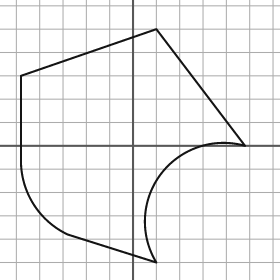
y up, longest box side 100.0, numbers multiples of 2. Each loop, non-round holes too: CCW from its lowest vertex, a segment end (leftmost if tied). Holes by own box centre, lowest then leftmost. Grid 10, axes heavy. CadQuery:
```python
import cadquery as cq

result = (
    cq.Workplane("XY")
    .moveTo(10.0, -50.0)
    .threePointArc((12.0, -12.0), (48.0, 0.0))
    .lineTo(10.0, 50.0)
    .lineTo(-48.0, 30.0)
    .lineTo(-48.0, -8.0)
    .threePointArc((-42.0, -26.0), (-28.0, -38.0))
    .close()
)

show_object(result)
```